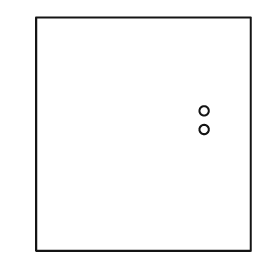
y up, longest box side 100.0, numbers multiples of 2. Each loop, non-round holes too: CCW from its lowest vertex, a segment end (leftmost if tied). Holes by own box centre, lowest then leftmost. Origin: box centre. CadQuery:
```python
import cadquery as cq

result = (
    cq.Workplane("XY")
    .moveTo(-46.0, -50.0)
    .lineTo(46.0, -50.0)
    .lineTo(46.0, 50.0)
    .lineTo(-46.0, 50.0)
    .close()
    .moveTo(26.0, 2.0)
    .circle(2.0)
    .moveTo(26.0, 10.0)
    .circle(2.0)
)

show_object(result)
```